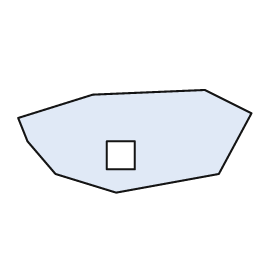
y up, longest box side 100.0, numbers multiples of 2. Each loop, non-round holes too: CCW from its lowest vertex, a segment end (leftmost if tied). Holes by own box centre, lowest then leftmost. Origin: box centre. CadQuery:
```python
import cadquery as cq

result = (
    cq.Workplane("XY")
    .moveTo(-8.0, -22.0)
    .lineTo(36.0, -14.0)
    .lineTo(50.0, 12.0)
    .lineTo(30.0, 22.0)
    .lineTo(-18.0, 20.0)
    .lineTo(-50.0, 10.0)
    .lineTo(-46.0, 0.0)
    .lineTo(-34.0, -14.0)
    .close()
    .moveTo(-12.0, -12.0)
    .lineTo(0.0, -12.0)
    .lineTo(0.0, 0.0)
    .lineTo(-12.0, 0.0)
    .close()
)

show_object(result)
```